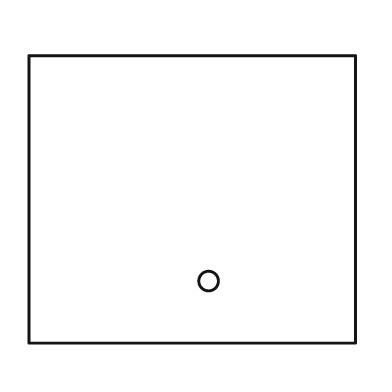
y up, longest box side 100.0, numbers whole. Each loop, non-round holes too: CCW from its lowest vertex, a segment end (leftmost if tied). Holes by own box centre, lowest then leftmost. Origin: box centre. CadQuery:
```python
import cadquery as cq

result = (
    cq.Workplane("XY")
    .moveTo(-50.0, -44.0)
    .lineTo(50.0, -44.0)
    .lineTo(50.0, 44.0)
    .lineTo(-50.0, 44.0)
    .close()
    .moveTo(5.0, -25.0)
    .circle(3.0)
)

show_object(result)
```